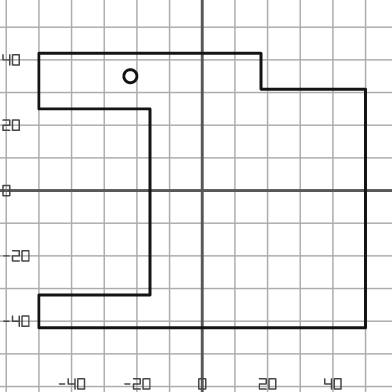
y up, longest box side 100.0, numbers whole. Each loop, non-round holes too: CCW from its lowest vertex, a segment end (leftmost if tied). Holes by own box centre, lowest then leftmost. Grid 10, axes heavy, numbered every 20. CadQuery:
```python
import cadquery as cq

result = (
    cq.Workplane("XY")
    .moveTo(-50.0, -42.0)
    .lineTo(50.0, -42.0)
    .lineTo(50.0, 31.0)
    .lineTo(18.0, 31.0)
    .lineTo(18.0, 42.0)
    .lineTo(-50.0, 42.0)
    .lineTo(-50.0, 25.0)
    .lineTo(-16.0, 25.0)
    .lineTo(-16.0, -32.0)
    .lineTo(-50.0, -32.0)
    .close()
    .moveTo(-22.0, 35.0)
    .circle(2.0)
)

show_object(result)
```